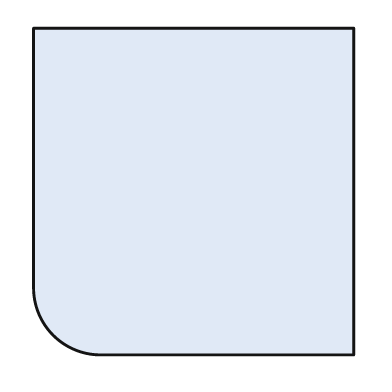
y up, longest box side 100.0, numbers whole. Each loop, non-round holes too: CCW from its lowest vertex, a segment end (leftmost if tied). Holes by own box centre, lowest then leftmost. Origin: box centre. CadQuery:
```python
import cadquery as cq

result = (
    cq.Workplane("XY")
    .moveTo(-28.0, -50.0)
    .lineTo(49.0, -50.0)
    .lineTo(49.0, 50.0)
    .lineTo(-49.0, 50.0)
    .lineTo(-49.0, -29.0)
    .threePointArc((-43.0, -44.0), (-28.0, -50.0))
    .close()
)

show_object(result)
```